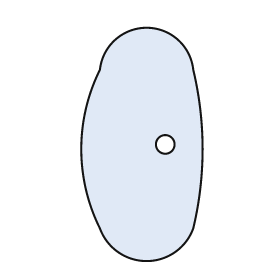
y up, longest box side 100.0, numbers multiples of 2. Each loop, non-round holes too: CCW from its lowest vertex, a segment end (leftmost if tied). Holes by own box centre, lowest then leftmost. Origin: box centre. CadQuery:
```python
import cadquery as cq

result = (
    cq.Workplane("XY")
    .moveTo(-18.0, -36.0)
    .threePointArc((2.0, -50.0), (22.0, -36.0))
    .threePointArc((26.0, -2.0), (22.0, 32.0))
    .threePointArc((2.0, 50.0), (-18.0, 32.0))
    .threePointArc((-26.0, -2.0), (-18.0, -36.0))
    .close()
    .moveTo(10.0, 0.0)
    .circle(4.0)
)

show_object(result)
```